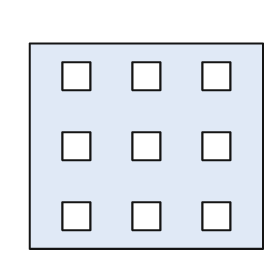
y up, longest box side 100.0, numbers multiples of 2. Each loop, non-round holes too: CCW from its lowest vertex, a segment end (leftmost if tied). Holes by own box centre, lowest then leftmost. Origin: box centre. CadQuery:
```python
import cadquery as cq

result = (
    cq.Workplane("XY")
    .moveTo(-50.0, -44.0)
    .lineTo(50.0, -44.0)
    .lineTo(50.0, 44.0)
    .lineTo(-50.0, 44.0)
    .close()
    .moveTo(-36.0, -36.0)
    .lineTo(-24.0, -36.0)
    .lineTo(-24.0, -24.0)
    .lineTo(-36.0, -24.0)
    .close()
    .moveTo(-6.0, -36.0)
    .lineTo(6.0, -36.0)
    .lineTo(6.0, -24.0)
    .lineTo(-6.0, -24.0)
    .close()
    .moveTo(24.0, -36.0)
    .lineTo(36.0, -36.0)
    .lineTo(36.0, -24.0)
    .lineTo(24.0, -24.0)
    .close()
    .moveTo(-36.0, -6.0)
    .lineTo(-24.0, -6.0)
    .lineTo(-24.0, 6.0)
    .lineTo(-36.0, 6.0)
    .close()
    .moveTo(-6.0, -6.0)
    .lineTo(6.0, -6.0)
    .lineTo(6.0, 6.0)
    .lineTo(-6.0, 6.0)
    .close()
    .moveTo(24.0, -6.0)
    .lineTo(36.0, -6.0)
    .lineTo(36.0, 6.0)
    .lineTo(24.0, 6.0)
    .close()
    .moveTo(-36.0, 24.0)
    .lineTo(-24.0, 24.0)
    .lineTo(-24.0, 36.0)
    .lineTo(-36.0, 36.0)
    .close()
    .moveTo(-6.0, 24.0)
    .lineTo(6.0, 24.0)
    .lineTo(6.0, 36.0)
    .lineTo(-6.0, 36.0)
    .close()
    .moveTo(24.0, 24.0)
    .lineTo(36.0, 24.0)
    .lineTo(36.0, 36.0)
    .lineTo(24.0, 36.0)
    .close()
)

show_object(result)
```